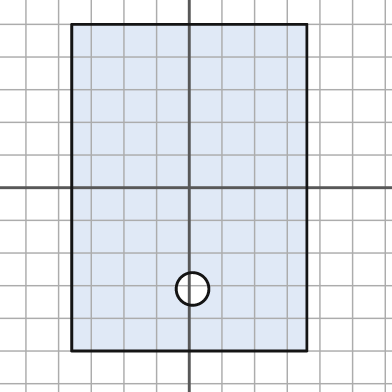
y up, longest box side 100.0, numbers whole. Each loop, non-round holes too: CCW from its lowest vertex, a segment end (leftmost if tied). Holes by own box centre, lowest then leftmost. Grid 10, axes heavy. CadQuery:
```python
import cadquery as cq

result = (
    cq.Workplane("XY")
    .moveTo(-36.0, -50.0)
    .lineTo(36.0, -50.0)
    .lineTo(36.0, 50.0)
    .lineTo(-36.0, 50.0)
    .close()
    .moveTo(1.0, -31.0)
    .circle(5.0)
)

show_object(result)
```